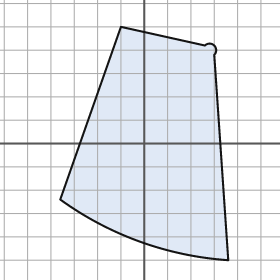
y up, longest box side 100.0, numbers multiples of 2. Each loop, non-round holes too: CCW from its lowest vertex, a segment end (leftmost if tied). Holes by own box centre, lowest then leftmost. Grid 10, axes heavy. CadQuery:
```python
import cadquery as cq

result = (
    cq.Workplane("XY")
    .moveTo(36.0, -50.0)
    .lineTo(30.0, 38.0)
    .threePointArc((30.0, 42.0), (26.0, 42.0))
    .lineTo(-10.0, 50.0)
    .lineTo(-36.0, -24.0)
    .threePointArc((-2.0, -42.0), (36.0, -50.0))
    .close()
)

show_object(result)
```